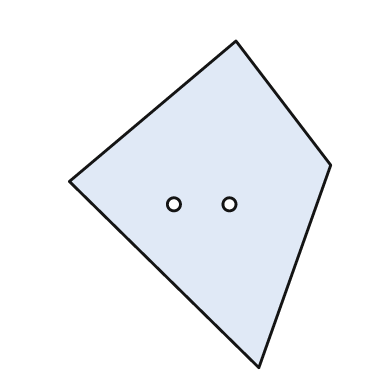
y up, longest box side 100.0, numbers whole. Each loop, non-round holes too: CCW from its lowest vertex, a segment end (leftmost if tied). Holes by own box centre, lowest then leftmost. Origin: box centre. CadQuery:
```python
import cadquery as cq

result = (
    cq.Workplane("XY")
    .moveTo(18.0, -50.0)
    .lineTo(40.0, 12.0)
    .lineTo(11.0, 50.0)
    .lineTo(-40.0, 7.0)
    .close()
    .moveTo(-8.0, 0.0)
    .circle(2.0)
    .moveTo(9.0, 0.0)
    .circle(2.0)
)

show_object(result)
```